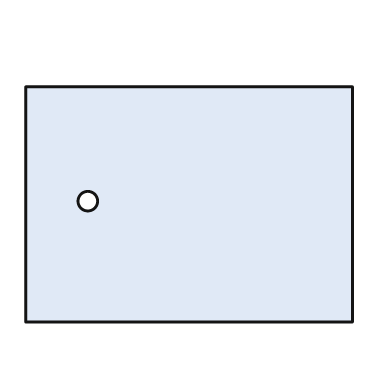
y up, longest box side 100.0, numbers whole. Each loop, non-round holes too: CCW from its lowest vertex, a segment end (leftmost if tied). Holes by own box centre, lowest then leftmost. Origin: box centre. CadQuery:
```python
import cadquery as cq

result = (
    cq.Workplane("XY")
    .moveTo(-50.0, -36.0)
    .lineTo(50.0, -36.0)
    .lineTo(50.0, 36.0)
    .lineTo(-50.0, 36.0)
    .close()
    .moveTo(-31.0, 1.0)
    .circle(3.0)
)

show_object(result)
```